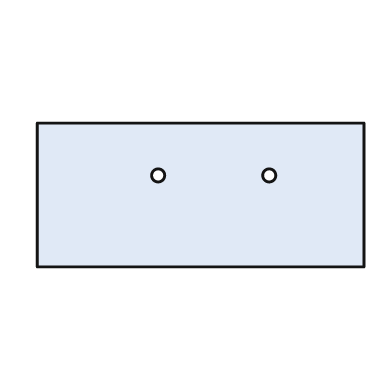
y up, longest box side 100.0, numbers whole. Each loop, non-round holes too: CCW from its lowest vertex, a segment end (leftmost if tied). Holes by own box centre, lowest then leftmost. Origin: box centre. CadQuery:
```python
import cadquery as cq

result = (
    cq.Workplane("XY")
    .moveTo(-50.0, -22.0)
    .lineTo(50.0, -22.0)
    .lineTo(50.0, 22.0)
    .lineTo(-50.0, 22.0)
    .close()
    .moveTo(-13.0, 6.0)
    .circle(2.0)
    .moveTo(21.0, 6.0)
    .circle(2.0)
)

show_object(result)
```